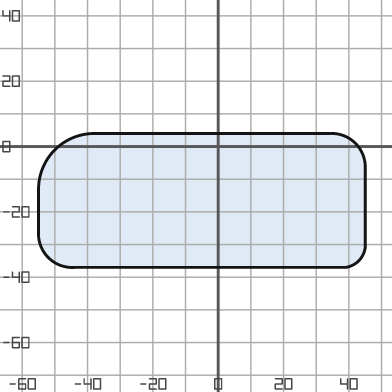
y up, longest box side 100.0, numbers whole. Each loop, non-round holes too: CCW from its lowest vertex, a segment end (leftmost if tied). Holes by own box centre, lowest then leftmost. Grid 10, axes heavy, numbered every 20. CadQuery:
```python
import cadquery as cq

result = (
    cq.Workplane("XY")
    .moveTo(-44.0, -37.0)
    .lineTo(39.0, -37.0)
    .threePointArc((43.0, -35.0), (45.0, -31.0))
    .lineTo(45.0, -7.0)
    .threePointArc((42.0, 1.0), (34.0, 4.0))
    .lineTo(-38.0, 4.0)
    .threePointArc((-50.0, -1.0), (-55.0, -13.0))
    .lineTo(-55.0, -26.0)
    .threePointArc((-52.0, -34.0), (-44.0, -37.0))
    .close()
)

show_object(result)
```